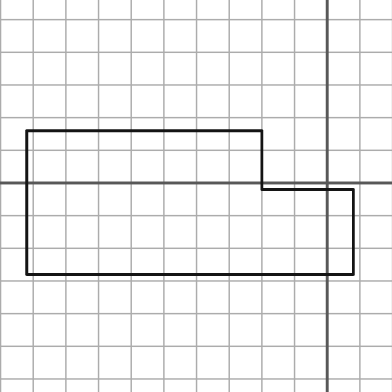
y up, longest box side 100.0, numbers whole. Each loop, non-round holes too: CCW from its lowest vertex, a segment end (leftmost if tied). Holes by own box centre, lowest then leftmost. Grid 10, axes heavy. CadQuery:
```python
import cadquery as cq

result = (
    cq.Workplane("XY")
    .moveTo(-92.0, -28.0)
    .lineTo(8.0, -28.0)
    .lineTo(8.0, -2.0)
    .lineTo(-20.0, -2.0)
    .lineTo(-20.0, 16.0)
    .lineTo(-92.0, 16.0)
    .close()
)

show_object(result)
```